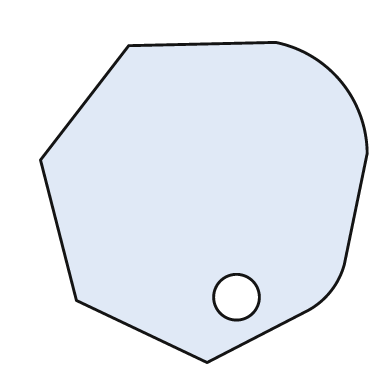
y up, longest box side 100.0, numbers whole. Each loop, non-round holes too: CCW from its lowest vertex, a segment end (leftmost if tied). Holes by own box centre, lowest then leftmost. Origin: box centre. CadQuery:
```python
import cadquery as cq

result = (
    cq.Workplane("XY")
    .moveTo(1.0, -49.0)
    .lineTo(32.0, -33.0)
    .threePointArc((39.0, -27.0), (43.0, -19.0))
    .lineTo(50.0, 15.0)
    .threePointArc((42.0, 37.0), (22.0, 49.0))
    .lineTo(-23.0, 48.0)
    .lineTo(-50.0, 13.0)
    .lineTo(-39.0, -30.0)
    .close()
    .moveTo(10.0, -29.0)
    .circle(7.0)
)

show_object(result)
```